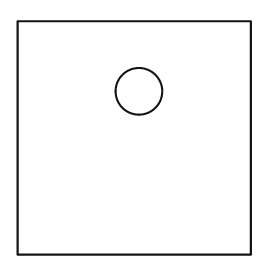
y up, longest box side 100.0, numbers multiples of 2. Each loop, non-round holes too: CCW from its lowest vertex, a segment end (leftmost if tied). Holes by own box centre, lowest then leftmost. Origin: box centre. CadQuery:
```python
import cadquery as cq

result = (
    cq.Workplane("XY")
    .moveTo(-50.0, -50.0)
    .lineTo(50.0, -50.0)
    .lineTo(50.0, 50.0)
    .lineTo(-50.0, 50.0)
    .close()
    .moveTo(2.0, 20.0)
    .circle(10.0)
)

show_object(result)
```